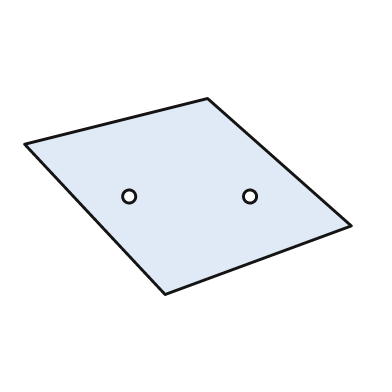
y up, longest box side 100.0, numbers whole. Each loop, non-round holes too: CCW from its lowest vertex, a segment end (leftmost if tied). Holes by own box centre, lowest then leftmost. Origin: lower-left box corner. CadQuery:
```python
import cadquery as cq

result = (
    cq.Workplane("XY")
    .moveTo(43.0, 0.0)
    .lineTo(100.0, 21.0)
    .lineTo(56.0, 60.0)
    .lineTo(0.0, 46.0)
    .close()
    .moveTo(32.0, 30.0)
    .circle(2.0)
    .moveTo(69.0, 30.0)
    .circle(2.0)
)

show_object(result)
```